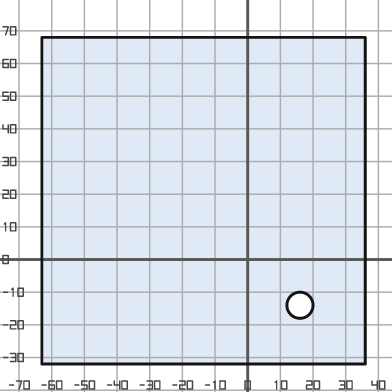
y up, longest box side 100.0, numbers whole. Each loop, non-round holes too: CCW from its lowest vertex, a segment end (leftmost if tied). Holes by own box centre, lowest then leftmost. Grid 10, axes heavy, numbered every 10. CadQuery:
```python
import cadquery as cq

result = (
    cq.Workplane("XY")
    .moveTo(-63.0, -32.0)
    .lineTo(36.0, -32.0)
    .lineTo(36.0, 68.0)
    .lineTo(-63.0, 68.0)
    .close()
    .moveTo(16.0, -14.0)
    .circle(4.0)
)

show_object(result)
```